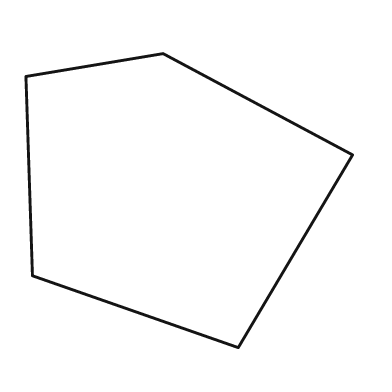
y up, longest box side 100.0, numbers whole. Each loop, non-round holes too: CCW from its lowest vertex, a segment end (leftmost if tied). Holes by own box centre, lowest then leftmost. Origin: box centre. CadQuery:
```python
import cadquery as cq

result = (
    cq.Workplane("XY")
    .moveTo(15.0, -45.0)
    .lineTo(50.0, 14.0)
    .lineTo(-8.0, 45.0)
    .lineTo(-50.0, 38.0)
    .lineTo(-48.0, -23.0)
    .close()
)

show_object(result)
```